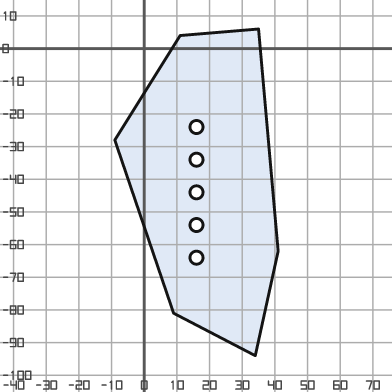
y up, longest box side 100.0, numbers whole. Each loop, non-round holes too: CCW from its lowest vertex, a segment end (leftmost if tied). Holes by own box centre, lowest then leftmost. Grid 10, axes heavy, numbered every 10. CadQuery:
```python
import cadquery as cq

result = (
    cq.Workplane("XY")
    .moveTo(34.0, -94.0)
    .lineTo(41.0, -62.0)
    .lineTo(35.0, 6.0)
    .lineTo(11.0, 4.0)
    .lineTo(-9.0, -28.0)
    .lineTo(9.0, -81.0)
    .close()
    .moveTo(16.0, -64.0)
    .circle(2.0)
    .moveTo(16.0, -54.0)
    .circle(2.0)
    .moveTo(16.0, -44.0)
    .circle(2.0)
    .moveTo(16.0, -34.0)
    .circle(2.0)
    .moveTo(16.0, -24.0)
    .circle(2.0)
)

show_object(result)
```